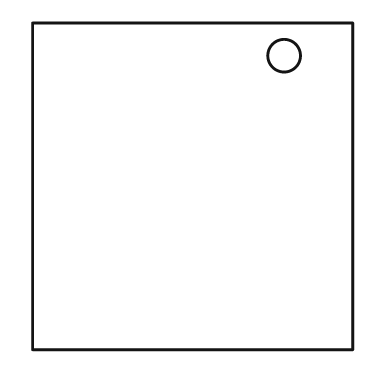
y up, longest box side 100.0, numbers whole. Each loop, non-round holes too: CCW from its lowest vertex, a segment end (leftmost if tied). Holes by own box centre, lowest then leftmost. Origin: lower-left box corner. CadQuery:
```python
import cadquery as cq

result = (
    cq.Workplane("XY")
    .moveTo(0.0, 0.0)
    .lineTo(98.0, 0.0)
    .lineTo(98.0, 100.0)
    .lineTo(0.0, 100.0)
    .close()
    .moveTo(77.0, 90.0)
    .circle(5.0)
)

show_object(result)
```